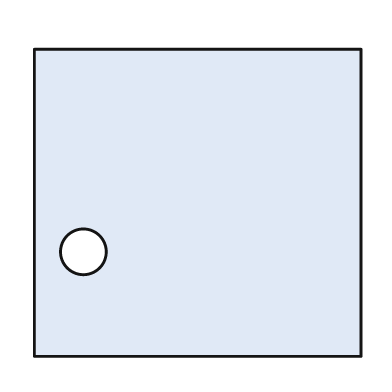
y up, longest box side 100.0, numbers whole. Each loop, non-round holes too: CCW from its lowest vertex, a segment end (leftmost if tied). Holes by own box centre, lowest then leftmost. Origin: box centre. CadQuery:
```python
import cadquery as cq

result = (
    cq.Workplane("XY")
    .moveTo(-50.0, -47.0)
    .lineTo(50.0, -47.0)
    .lineTo(50.0, 47.0)
    .lineTo(-50.0, 47.0)
    .close()
    .moveTo(-35.0, -15.0)
    .circle(7.0)
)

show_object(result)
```